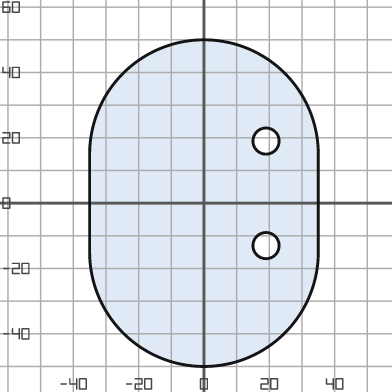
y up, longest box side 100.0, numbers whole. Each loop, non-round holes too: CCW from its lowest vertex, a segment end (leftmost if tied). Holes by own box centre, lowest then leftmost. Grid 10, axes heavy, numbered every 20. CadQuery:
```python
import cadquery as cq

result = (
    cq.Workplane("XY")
    .moveTo(-35.0, -15.0)
    .threePointArc((0.0, -50.0), (35.0, -15.0))
    .lineTo(35.0, 15.0)
    .threePointArc((0.0, 50.0), (-35.0, 15.0))
    .close()
    .moveTo(19.0, -13.0)
    .circle(4.0)
    .moveTo(19.0, 19.0)
    .circle(4.0)
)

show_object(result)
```